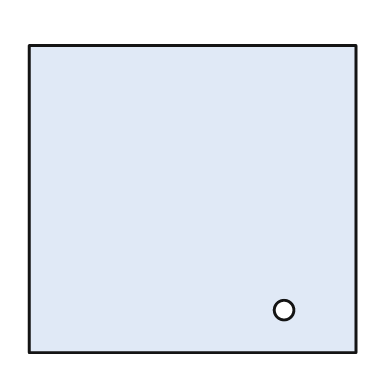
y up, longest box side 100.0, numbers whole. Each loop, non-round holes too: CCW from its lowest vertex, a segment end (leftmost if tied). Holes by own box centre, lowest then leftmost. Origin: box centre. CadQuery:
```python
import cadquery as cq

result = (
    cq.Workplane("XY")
    .moveTo(-50.0, -47.0)
    .lineTo(50.0, -47.0)
    .lineTo(50.0, 47.0)
    .lineTo(-50.0, 47.0)
    .close()
    .moveTo(28.0, -34.0)
    .circle(3.0)
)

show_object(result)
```